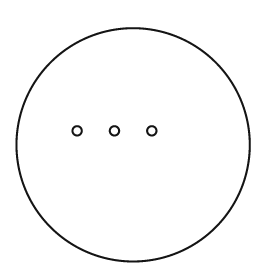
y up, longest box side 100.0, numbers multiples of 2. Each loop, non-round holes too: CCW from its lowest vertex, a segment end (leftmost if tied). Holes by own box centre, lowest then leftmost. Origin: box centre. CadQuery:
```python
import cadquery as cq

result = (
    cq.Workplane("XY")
    .moveTo(0.0, 0.0)
    .circle(50.0)
    .moveTo(-24.0, 6.0)
    .circle(2.0)
    .moveTo(-8.0, 6.0)
    .circle(2.0)
    .moveTo(8.0, 6.0)
    .circle(2.0)
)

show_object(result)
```